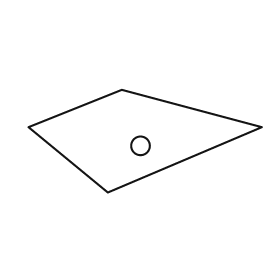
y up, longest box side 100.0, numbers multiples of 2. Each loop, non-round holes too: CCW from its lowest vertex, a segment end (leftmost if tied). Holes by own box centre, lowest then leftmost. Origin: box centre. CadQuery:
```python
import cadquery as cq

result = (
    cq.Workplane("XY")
    .moveTo(-16.0, -22.0)
    .lineTo(50.0, 6.0)
    .lineTo(-10.0, 22.0)
    .lineTo(-50.0, 6.0)
    .close()
    .moveTo(-2.0, -2.0)
    .circle(4.0)
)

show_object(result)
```